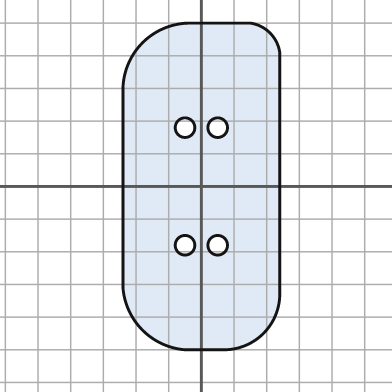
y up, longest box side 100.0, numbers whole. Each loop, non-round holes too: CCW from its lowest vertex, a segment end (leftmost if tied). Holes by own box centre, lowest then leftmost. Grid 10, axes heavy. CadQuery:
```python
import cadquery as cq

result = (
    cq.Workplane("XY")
    .moveTo(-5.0, -50.0)
    .lineTo(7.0, -50.0)
    .threePointArc((19.0, -45.0), (24.0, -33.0))
    .lineTo(24.0, 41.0)
    .threePointArc((21.0, 47.0), (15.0, 50.0))
    .lineTo(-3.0, 50.0)
    .threePointArc((-18.0, 44.0), (-24.0, 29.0))
    .lineTo(-24.0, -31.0)
    .threePointArc((-18.0, -44.0), (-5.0, -50.0))
    .close()
    .moveTo(-5.0, -18.0)
    .circle(3.0)
    .moveTo(5.0, -18.0)
    .circle(3.0)
    .moveTo(-5.0, 18.0)
    .circle(3.0)
    .moveTo(5.0, 18.0)
    .circle(3.0)
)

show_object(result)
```